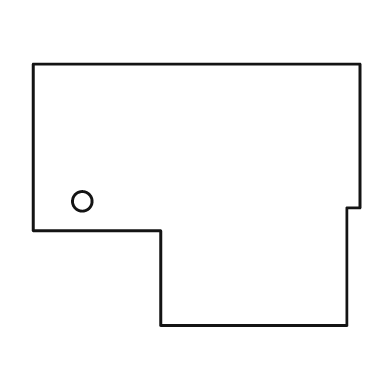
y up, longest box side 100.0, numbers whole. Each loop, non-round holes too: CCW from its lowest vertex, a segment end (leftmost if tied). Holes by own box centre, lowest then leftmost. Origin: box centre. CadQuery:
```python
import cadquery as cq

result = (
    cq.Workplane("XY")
    .moveTo(-11.0, -40.0)
    .lineTo(46.0, -40.0)
    .lineTo(46.0, -4.0)
    .lineTo(50.0, -4.0)
    .lineTo(50.0, 40.0)
    .lineTo(-50.0, 40.0)
    .lineTo(-50.0, -11.0)
    .lineTo(-11.0, -11.0)
    .close()
    .moveTo(-35.0, -2.0)
    .circle(3.0)
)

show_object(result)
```